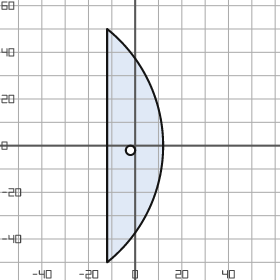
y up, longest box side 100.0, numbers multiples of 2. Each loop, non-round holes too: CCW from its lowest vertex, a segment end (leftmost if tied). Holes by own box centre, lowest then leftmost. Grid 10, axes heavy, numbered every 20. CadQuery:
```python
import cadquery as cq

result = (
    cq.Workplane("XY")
    .moveTo(-12.0, -50.0)
    .threePointArc((12.0, 0.0), (-12.0, 50.0))
    .close()
    .moveTo(-2.0, -2.0)
    .circle(2.0)
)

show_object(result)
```